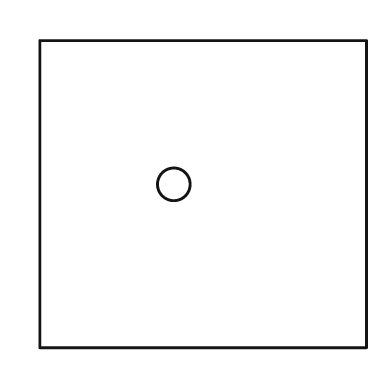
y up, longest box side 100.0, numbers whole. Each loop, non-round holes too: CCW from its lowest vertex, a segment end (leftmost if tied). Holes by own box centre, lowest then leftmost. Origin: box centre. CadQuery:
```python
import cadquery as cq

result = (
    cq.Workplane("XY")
    .moveTo(-50.0, -47.0)
    .lineTo(50.0, -47.0)
    .lineTo(50.0, 47.0)
    .lineTo(-50.0, 47.0)
    .close()
    .moveTo(-9.0, 3.0)
    .circle(5.0)
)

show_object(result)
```